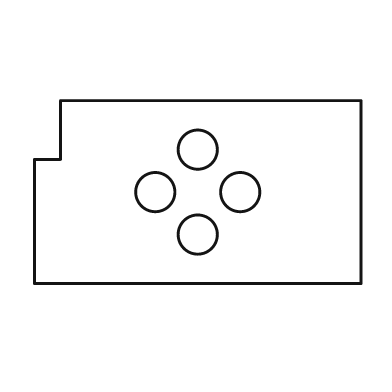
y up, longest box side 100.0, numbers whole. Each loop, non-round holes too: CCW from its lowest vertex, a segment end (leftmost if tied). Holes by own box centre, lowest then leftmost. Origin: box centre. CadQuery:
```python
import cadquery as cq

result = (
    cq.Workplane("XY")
    .moveTo(-50.0, -28.0)
    .lineTo(50.0, -28.0)
    .lineTo(50.0, 28.0)
    .lineTo(-42.0, 28.0)
    .lineTo(-42.0, 10.0)
    .lineTo(-50.0, 10.0)
    .close()
    .moveTo(0.0, -13.0)
    .circle(6.0)
    .moveTo(-13.0, 0.0)
    .circle(6.0)
    .moveTo(13.0, 0.0)
    .circle(6.0)
    .moveTo(0.0, 13.0)
    .circle(6.0)
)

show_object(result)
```